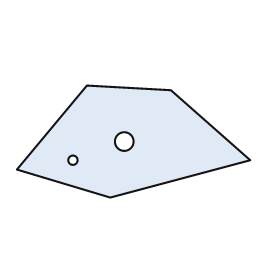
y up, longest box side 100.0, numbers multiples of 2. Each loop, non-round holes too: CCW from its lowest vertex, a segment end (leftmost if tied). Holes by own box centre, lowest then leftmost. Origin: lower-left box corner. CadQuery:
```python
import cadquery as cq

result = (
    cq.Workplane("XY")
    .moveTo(40.0, 0.0)
    .lineTo(100.0, 16.0)
    .lineTo(66.0, 46.0)
    .lineTo(30.0, 48.0)
    .lineTo(0.0, 12.0)
    .close()
    .moveTo(24.0, 16.0)
    .circle(2.0)
    .moveTo(46.0, 24.0)
    .circle(4.0)
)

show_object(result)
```